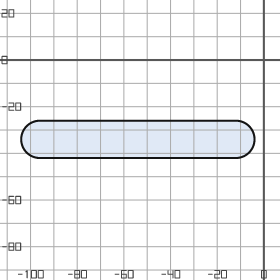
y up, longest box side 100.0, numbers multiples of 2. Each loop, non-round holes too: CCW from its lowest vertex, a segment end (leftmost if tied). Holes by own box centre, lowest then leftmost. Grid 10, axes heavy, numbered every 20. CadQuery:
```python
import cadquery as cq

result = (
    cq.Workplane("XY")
    .moveTo(-96.0, -42.0)
    .lineTo(-12.0, -42.0)
    .threePointArc((-4.0, -34.0), (-12.0, -26.0))
    .lineTo(-96.0, -26.0)
    .threePointArc((-104.0, -34.0), (-96.0, -42.0))
    .close()
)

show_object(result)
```